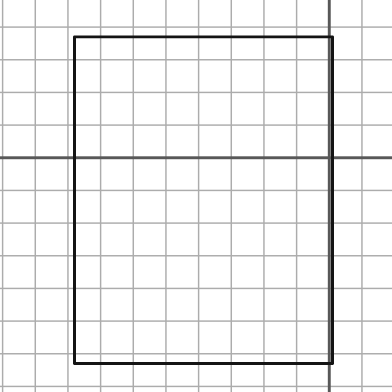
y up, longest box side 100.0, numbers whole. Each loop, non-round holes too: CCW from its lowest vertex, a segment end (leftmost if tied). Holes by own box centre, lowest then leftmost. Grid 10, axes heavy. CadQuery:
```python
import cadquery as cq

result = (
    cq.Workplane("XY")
    .moveTo(-78.0, -63.0)
    .lineTo(1.0, -63.0)
    .lineTo(1.0, 37.0)
    .lineTo(-78.0, 37.0)
    .close()
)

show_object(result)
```